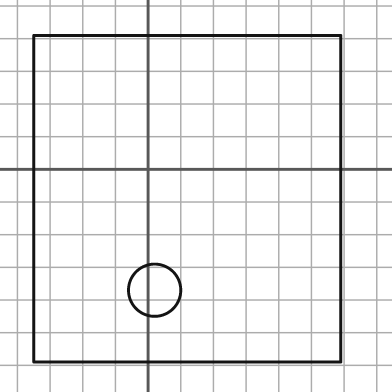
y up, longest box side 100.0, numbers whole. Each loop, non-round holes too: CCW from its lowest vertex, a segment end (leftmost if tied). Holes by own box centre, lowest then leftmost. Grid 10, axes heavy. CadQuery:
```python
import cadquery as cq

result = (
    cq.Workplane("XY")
    .moveTo(-35.0, -59.0)
    .lineTo(59.0, -59.0)
    .lineTo(59.0, 41.0)
    .lineTo(-35.0, 41.0)
    .close()
    .moveTo(2.0, -37.0)
    .circle(8.0)
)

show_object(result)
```